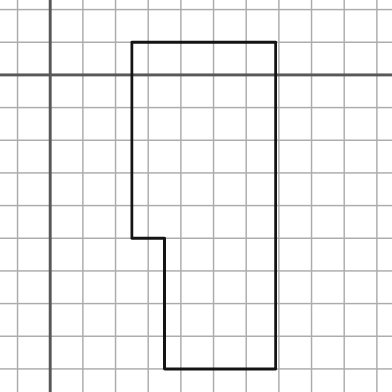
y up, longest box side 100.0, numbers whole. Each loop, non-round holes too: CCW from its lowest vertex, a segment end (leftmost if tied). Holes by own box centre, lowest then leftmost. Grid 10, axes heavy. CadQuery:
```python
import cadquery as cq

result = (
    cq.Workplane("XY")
    .moveTo(35.0, -90.0)
    .lineTo(69.0, -90.0)
    .lineTo(69.0, 10.0)
    .lineTo(25.0, 10.0)
    .lineTo(25.0, -50.0)
    .lineTo(35.0, -50.0)
    .close()
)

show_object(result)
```